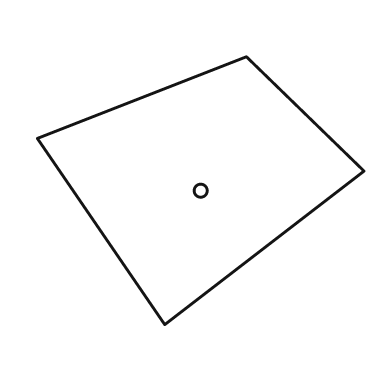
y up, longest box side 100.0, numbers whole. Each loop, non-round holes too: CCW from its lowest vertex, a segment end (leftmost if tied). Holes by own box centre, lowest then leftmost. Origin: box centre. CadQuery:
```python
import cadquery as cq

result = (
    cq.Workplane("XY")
    .moveTo(-11.0, -41.0)
    .lineTo(50.0, 6.0)
    .lineTo(14.0, 41.0)
    .lineTo(-50.0, 16.0)
    .close()
    .moveTo(0.0, 0.0)
    .circle(2.0)
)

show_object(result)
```